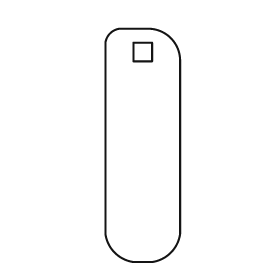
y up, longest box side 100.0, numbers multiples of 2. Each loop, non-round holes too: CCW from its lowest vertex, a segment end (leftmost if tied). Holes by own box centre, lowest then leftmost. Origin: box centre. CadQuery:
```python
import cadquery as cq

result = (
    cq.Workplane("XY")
    .moveTo(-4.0, -50.0)
    .lineTo(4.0, -50.0)
    .threePointArc((12.0, -46.0), (16.0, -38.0))
    .lineTo(16.0, 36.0)
    .threePointArc((12.0, 46.0), (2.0, 50.0))
    .lineTo(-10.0, 50.0)
    .threePointArc((-14.0, 48.0), (-16.0, 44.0))
    .lineTo(-16.0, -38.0)
    .threePointArc((-12.0, -46.0), (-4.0, -50.0))
    .close()
    .moveTo(-4.0, 36.0)
    .lineTo(4.0, 36.0)
    .lineTo(4.0, 44.0)
    .lineTo(-4.0, 44.0)
    .close()
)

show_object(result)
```